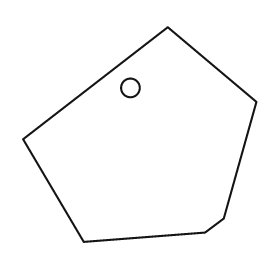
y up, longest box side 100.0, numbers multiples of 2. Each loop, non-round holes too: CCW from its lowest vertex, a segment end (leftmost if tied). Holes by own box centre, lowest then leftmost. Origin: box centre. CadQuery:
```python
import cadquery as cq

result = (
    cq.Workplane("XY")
    .moveTo(-24.0, -46.0)
    .lineTo(28.0, -42.0)
    .lineTo(36.0, -36.0)
    .lineTo(50.0, 14.0)
    .lineTo(12.0, 46.0)
    .lineTo(-50.0, -2.0)
    .close()
    .moveTo(-4.0, 20.0)
    .circle(4.0)
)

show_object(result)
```